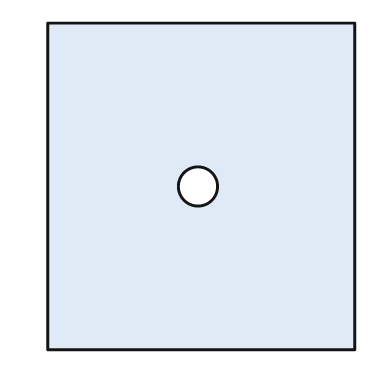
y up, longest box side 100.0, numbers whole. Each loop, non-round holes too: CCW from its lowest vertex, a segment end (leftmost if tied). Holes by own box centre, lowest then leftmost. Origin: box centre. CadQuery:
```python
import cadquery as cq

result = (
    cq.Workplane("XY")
    .moveTo(-47.0, -50.0)
    .lineTo(47.0, -50.0)
    .lineTo(47.0, 50.0)
    .lineTo(-47.0, 50.0)
    .close()
    .moveTo(-1.0, 0.0)
    .circle(6.0)
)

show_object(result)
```